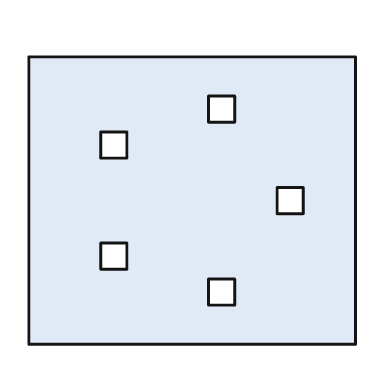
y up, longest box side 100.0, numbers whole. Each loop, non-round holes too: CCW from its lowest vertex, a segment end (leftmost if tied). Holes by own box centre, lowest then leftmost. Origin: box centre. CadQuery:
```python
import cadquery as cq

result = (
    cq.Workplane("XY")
    .moveTo(-50.0, -44.0)
    .lineTo(50.0, -44.0)
    .lineTo(50.0, 44.0)
    .lineTo(-50.0, 44.0)
    .close()
    .moveTo(5.0, -32.0)
    .lineTo(13.0, -32.0)
    .lineTo(13.0, -24.0)
    .lineTo(5.0, -24.0)
    .close()
    .moveTo(-28.0, -21.0)
    .lineTo(-20.0, -21.0)
    .lineTo(-20.0, -13.0)
    .lineTo(-28.0, -13.0)
    .close()
    .moveTo(26.0, -4.0)
    .lineTo(34.0, -4.0)
    .lineTo(34.0, 4.0)
    .lineTo(26.0, 4.0)
    .close()
    .moveTo(-28.0, 13.0)
    .lineTo(-20.0, 13.0)
    .lineTo(-20.0, 21.0)
    .lineTo(-28.0, 21.0)
    .close()
    .moveTo(5.0, 24.0)
    .lineTo(13.0, 24.0)
    .lineTo(13.0, 32.0)
    .lineTo(5.0, 32.0)
    .close()
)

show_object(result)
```